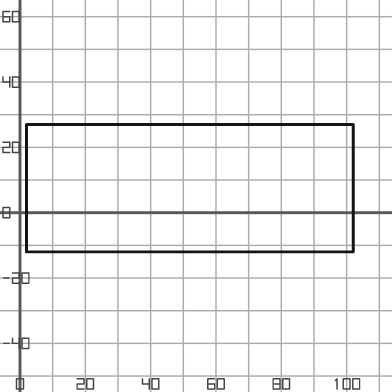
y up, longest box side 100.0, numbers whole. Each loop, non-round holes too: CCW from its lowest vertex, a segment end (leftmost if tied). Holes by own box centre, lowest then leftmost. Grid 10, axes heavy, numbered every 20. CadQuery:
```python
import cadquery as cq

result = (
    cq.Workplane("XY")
    .moveTo(2.0, -12.0)
    .lineTo(102.0, -12.0)
    .lineTo(102.0, 27.0)
    .lineTo(2.0, 27.0)
    .close()
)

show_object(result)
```